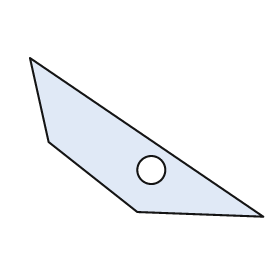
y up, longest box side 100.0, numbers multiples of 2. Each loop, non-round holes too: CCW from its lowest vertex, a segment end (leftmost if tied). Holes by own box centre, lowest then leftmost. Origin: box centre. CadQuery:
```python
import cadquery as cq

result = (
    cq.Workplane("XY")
    .moveTo(50.0, -34.0)
    .lineTo(-50.0, 34.0)
    .lineTo(-42.0, -2.0)
    .lineTo(-4.0, -32.0)
    .close()
    .moveTo(2.0, -14.0)
    .circle(6.0)
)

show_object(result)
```